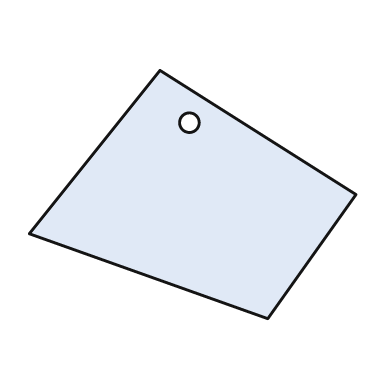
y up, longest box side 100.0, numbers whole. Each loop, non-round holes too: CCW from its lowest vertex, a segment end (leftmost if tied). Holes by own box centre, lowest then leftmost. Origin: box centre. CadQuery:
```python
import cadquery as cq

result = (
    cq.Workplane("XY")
    .moveTo(23.0, -38.0)
    .lineTo(50.0, 0.0)
    .lineTo(-10.0, 38.0)
    .lineTo(-50.0, -12.0)
    .close()
    .moveTo(-1.0, 22.0)
    .circle(3.0)
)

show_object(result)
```